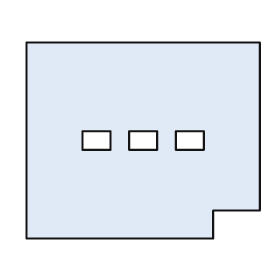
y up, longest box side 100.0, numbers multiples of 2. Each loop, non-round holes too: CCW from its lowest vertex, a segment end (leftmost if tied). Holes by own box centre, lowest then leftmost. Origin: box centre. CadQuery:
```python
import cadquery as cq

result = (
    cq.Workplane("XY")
    .moveTo(-50.0, -42.0)
    .lineTo(30.0, -42.0)
    .lineTo(30.0, -30.0)
    .lineTo(50.0, -30.0)
    .lineTo(50.0, 42.0)
    .lineTo(-50.0, 42.0)
    .close()
    .moveTo(-26.0, -4.0)
    .lineTo(-14.0, -4.0)
    .lineTo(-14.0, 4.0)
    .lineTo(-26.0, 4.0)
    .close()
    .moveTo(-6.0, -4.0)
    .lineTo(6.0, -4.0)
    .lineTo(6.0, 4.0)
    .lineTo(-6.0, 4.0)
    .close()
    .moveTo(14.0, -4.0)
    .lineTo(26.0, -4.0)
    .lineTo(26.0, 4.0)
    .lineTo(14.0, 4.0)
    .close()
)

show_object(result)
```